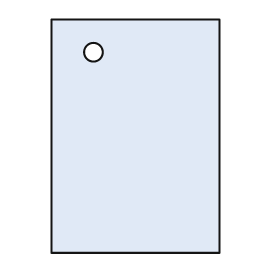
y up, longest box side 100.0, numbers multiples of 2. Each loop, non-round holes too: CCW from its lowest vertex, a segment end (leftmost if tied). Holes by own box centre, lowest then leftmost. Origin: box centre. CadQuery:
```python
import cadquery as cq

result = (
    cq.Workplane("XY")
    .moveTo(-36.0, -50.0)
    .lineTo(36.0, -50.0)
    .lineTo(36.0, 50.0)
    .lineTo(-36.0, 50.0)
    .close()
    .moveTo(-18.0, 36.0)
    .circle(4.0)
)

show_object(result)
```